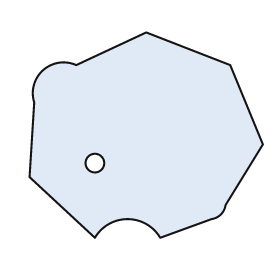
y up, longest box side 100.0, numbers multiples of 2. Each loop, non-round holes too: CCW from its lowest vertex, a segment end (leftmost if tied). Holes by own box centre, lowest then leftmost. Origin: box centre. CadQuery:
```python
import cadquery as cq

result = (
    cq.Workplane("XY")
    .moveTo(-22.0, -44.0)
    .threePointArc((-8.0, -36.0), (6.0, -44.0))
    .lineTo(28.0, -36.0)
    .threePointArc((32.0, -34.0), (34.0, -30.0))
    .lineTo(50.0, -4.0)
    .lineTo(36.0, 30.0)
    .lineTo(0.0, 44.0)
    .lineTo(-30.0, 30.0)
    .threePointArc((-44.0, 28.0), (-48.0, 14.0))
    .lineTo(-50.0, -18.0)
    .close()
    .moveTo(-22.0, -12.0)
    .circle(4.0)
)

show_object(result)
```